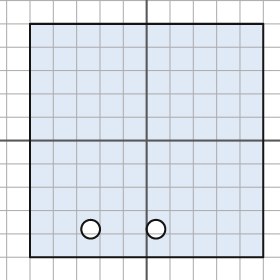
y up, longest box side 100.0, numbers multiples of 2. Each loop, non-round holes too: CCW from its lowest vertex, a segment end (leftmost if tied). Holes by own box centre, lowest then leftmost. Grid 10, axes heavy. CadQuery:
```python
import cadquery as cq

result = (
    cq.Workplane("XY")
    .moveTo(-50.0, -50.0)
    .lineTo(50.0, -50.0)
    .lineTo(50.0, 50.0)
    .lineTo(-50.0, 50.0)
    .close()
    .moveTo(-24.0, -38.0)
    .circle(4.0)
    .moveTo(4.0, -38.0)
    .circle(4.0)
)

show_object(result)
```